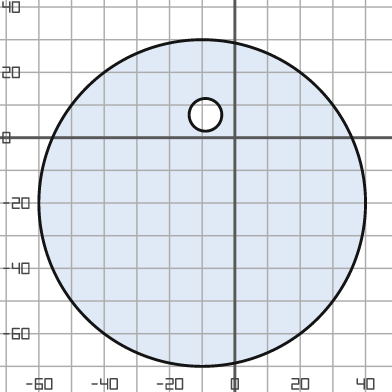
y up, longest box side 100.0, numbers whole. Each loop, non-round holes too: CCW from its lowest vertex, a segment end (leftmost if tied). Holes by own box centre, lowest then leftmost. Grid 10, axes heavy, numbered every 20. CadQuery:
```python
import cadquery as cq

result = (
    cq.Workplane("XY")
    .moveTo(-10.0, -20.0)
    .circle(50.0)
    .moveTo(-9.0, 7.0)
    .circle(5.0)
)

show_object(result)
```